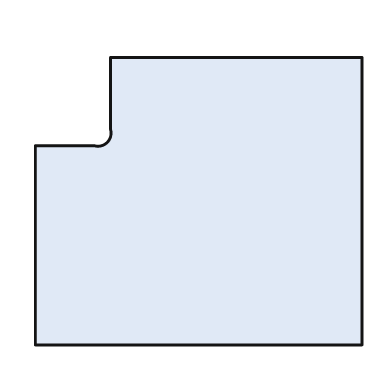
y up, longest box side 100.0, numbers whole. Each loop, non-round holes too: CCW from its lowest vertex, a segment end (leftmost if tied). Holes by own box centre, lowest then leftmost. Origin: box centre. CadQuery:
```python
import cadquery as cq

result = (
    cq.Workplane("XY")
    .moveTo(-50.0, -44.0)
    .lineTo(50.0, -44.0)
    .lineTo(50.0, 44.0)
    .lineTo(-27.0, 44.0)
    .lineTo(-27.0, 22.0)
    .threePointArc((-28.0, 18.0), (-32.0, 17.0))
    .lineTo(-50.0, 17.0)
    .close()
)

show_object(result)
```